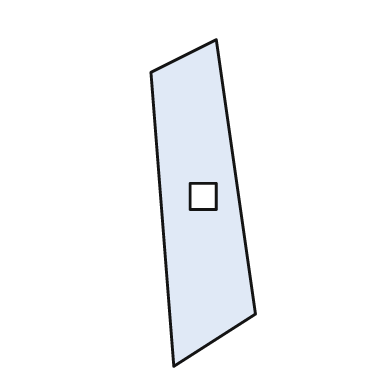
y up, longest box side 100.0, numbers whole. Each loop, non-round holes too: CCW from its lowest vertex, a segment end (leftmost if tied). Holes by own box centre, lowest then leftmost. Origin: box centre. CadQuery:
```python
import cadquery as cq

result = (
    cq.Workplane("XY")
    .moveTo(-9.0, -50.0)
    .lineTo(16.0, -34.0)
    .lineTo(4.0, 50.0)
    .lineTo(-16.0, 40.0)
    .close()
    .moveTo(-4.0, -2.0)
    .lineTo(4.0, -2.0)
    .lineTo(4.0, 6.0)
    .lineTo(-4.0, 6.0)
    .close()
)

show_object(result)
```